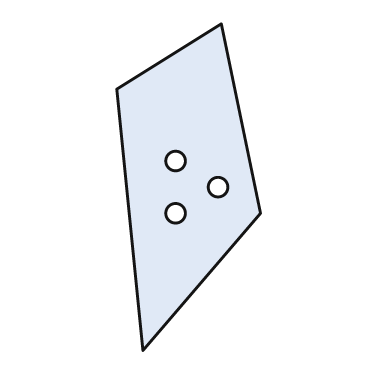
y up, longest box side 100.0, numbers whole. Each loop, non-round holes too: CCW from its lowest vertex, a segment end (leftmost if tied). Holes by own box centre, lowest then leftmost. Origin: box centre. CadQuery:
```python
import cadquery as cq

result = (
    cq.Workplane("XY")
    .moveTo(-14.0, -50.0)
    .lineTo(22.0, -8.0)
    .lineTo(10.0, 50.0)
    .lineTo(-22.0, 30.0)
    .close()
    .moveTo(-4.0, -8.0)
    .circle(3.0)
    .moveTo(9.0, 0.0)
    .circle(3.0)
    .moveTo(-4.0, 8.0)
    .circle(3.0)
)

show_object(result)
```